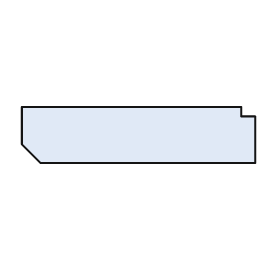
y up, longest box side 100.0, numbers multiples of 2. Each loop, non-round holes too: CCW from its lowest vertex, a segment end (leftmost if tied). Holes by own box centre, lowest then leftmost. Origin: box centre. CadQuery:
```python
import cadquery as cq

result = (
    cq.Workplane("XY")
    .moveTo(-42.0, -12.0)
    .lineTo(50.0, -12.0)
    .lineTo(50.0, 8.0)
    .lineTo(44.0, 8.0)
    .lineTo(44.0, 12.0)
    .lineTo(-50.0, 12.0)
    .lineTo(-50.0, -4.0)
    .close()
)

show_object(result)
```